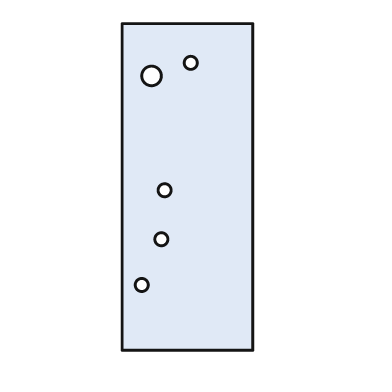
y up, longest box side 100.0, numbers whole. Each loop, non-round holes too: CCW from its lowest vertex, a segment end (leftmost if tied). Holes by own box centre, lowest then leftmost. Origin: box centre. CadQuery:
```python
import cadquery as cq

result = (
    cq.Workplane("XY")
    .moveTo(-20.0, -50.0)
    .lineTo(20.0, -50.0)
    .lineTo(20.0, 50.0)
    .lineTo(-20.0, 50.0)
    .close()
    .moveTo(-14.0, -30.0)
    .circle(2.0)
    .moveTo(-8.0, -16.0)
    .circle(2.0)
    .moveTo(-7.0, -1.0)
    .circle(2.0)
    .moveTo(-11.0, 34.0)
    .circle(3.0)
    .moveTo(1.0, 38.0)
    .circle(2.0)
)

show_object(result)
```